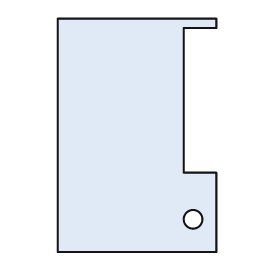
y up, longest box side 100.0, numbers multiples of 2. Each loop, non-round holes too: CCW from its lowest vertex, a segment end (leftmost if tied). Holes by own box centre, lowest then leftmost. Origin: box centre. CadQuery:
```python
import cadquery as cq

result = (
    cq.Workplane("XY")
    .moveTo(-34.0, -50.0)
    .lineTo(34.0, -50.0)
    .lineTo(34.0, -16.0)
    .lineTo(20.0, -16.0)
    .lineTo(20.0, 46.0)
    .lineTo(34.0, 46.0)
    .lineTo(34.0, 50.0)
    .lineTo(-34.0, 50.0)
    .close()
    .moveTo(24.0, -36.0)
    .circle(4.0)
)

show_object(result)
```